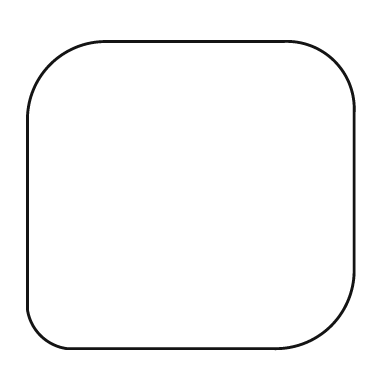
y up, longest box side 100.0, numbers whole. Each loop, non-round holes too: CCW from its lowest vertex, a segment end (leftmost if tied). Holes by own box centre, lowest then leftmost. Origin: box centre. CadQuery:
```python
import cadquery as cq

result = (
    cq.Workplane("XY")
    .moveTo(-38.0, -47.0)
    .lineTo(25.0, -47.0)
    .threePointArc((43.0, -40.0), (50.0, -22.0))
    .lineTo(50.0, 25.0)
    .threePointArc((44.0, 41.0), (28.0, 47.0))
    .lineTo(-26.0, 47.0)
    .threePointArc((-43.0, 40.0), (-50.0, 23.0))
    .lineTo(-50.0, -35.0)
    .threePointArc((-46.0, -43.0), (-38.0, -47.0))
    .close()
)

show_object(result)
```